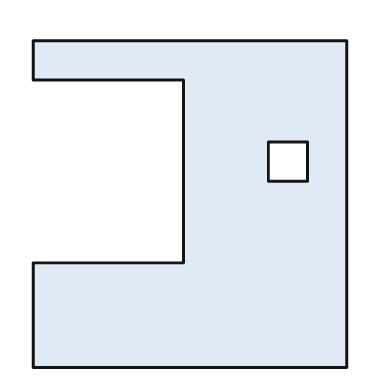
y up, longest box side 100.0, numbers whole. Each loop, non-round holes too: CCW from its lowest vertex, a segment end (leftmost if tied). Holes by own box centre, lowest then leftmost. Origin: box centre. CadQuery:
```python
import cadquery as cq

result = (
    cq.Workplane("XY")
    .moveTo(-48.0, -50.0)
    .lineTo(48.0, -50.0)
    .lineTo(48.0, 50.0)
    .lineTo(-48.0, 50.0)
    .lineTo(-48.0, 38.0)
    .lineTo(-2.0, 38.0)
    .lineTo(-2.0, -18.0)
    .lineTo(-48.0, -18.0)
    .close()
    .moveTo(24.0, 7.0)
    .lineTo(36.0, 7.0)
    .lineTo(36.0, 19.0)
    .lineTo(24.0, 19.0)
    .close()
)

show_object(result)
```